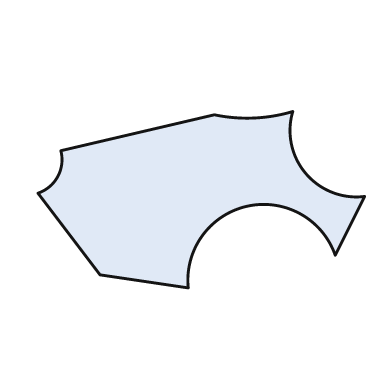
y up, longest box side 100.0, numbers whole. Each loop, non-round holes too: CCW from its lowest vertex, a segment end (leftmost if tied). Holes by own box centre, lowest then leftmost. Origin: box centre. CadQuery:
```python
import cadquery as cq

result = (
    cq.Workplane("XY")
    .moveTo(-4.0, -27.0)
    .threePointArc((14.0, -2.0), (41.0, -17.0))
    .lineTo(50.0, 1.0)
    .threePointArc((32.0, 8.0), (28.0, 27.0))
    .threePointArc((16.0, 25.0), (4.0, 26.0))
    .lineTo(-43.0, 15.0)
    .threePointArc((-44.0, 7.0), (-50.0, 2.0))
    .lineTo(-31.0, -23.0)
    .close()
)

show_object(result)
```